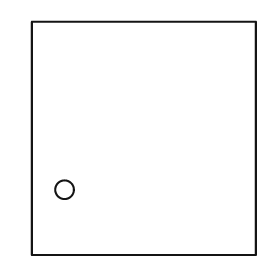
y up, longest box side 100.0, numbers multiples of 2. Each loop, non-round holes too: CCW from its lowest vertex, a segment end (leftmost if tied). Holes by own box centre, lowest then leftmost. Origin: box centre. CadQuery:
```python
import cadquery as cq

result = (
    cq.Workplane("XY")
    .moveTo(-48.0, -50.0)
    .lineTo(48.0, -50.0)
    .lineTo(48.0, 50.0)
    .lineTo(-48.0, 50.0)
    .close()
    .moveTo(-34.0, -22.0)
    .circle(4.0)
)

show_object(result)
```